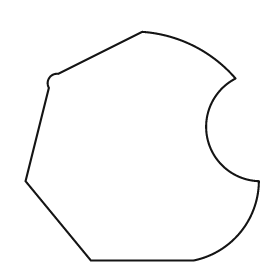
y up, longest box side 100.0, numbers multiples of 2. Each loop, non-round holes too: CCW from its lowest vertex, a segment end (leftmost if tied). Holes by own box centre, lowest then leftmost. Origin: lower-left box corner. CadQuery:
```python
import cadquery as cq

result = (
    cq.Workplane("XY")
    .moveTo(28.0, 0.0)
    .lineTo(72.0, 0.0)
    .threePointArc((92.0, 12.0), (100.0, 34.0))
    .threePointArc((78.0, 52.0), (90.0, 78.0))
    .threePointArc((72.0, 92.0), (50.0, 98.0))
    .lineTo(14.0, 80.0)
    .threePointArc((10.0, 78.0), (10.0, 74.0))
    .lineTo(0.0, 34.0)
    .close()
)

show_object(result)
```